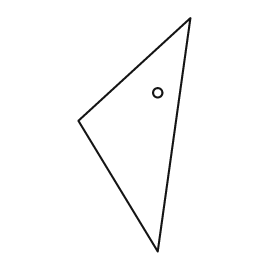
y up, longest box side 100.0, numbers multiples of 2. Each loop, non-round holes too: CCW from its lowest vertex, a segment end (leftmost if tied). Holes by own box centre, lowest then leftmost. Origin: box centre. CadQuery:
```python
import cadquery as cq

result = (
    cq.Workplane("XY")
    .moveTo(10.0, -50.0)
    .lineTo(24.0, 50.0)
    .lineTo(-24.0, 6.0)
    .close()
    .moveTo(10.0, 18.0)
    .circle(2.0)
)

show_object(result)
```